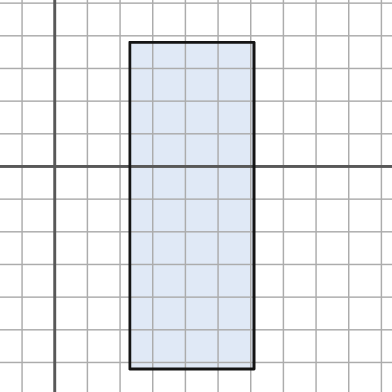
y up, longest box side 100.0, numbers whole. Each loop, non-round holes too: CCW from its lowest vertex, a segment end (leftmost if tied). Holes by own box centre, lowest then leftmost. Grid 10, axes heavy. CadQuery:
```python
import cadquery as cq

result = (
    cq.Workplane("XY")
    .moveTo(23.0, -62.0)
    .lineTo(61.0, -62.0)
    .lineTo(61.0, 38.0)
    .lineTo(23.0, 38.0)
    .close()
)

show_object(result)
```